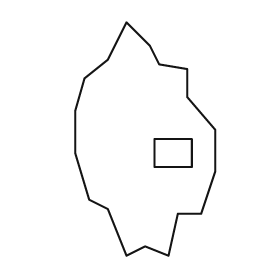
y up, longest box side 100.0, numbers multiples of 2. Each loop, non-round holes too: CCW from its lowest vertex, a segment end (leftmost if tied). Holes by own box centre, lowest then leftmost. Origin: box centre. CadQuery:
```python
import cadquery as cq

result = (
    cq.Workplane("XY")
    .moveTo(-8.0, -50.0)
    .lineTo(0.0, -46.0)
    .lineTo(10.0, -50.0)
    .lineTo(14.0, -32.0)
    .lineTo(24.0, -32.0)
    .lineTo(30.0, -14.0)
    .lineTo(30.0, 4.0)
    .lineTo(18.0, 18.0)
    .lineTo(18.0, 30.0)
    .lineTo(6.0, 32.0)
    .lineTo(2.0, 40.0)
    .lineTo(-8.0, 50.0)
    .lineTo(-16.0, 34.0)
    .lineTo(-26.0, 26.0)
    .lineTo(-30.0, 12.0)
    .lineTo(-30.0, -6.0)
    .lineTo(-24.0, -26.0)
    .lineTo(-16.0, -30.0)
    .close()
    .moveTo(4.0, -12.0)
    .lineTo(20.0, -12.0)
    .lineTo(20.0, 0.0)
    .lineTo(4.0, 0.0)
    .close()
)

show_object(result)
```